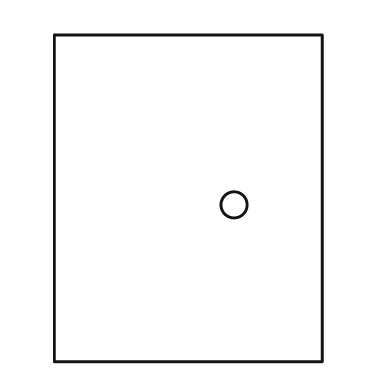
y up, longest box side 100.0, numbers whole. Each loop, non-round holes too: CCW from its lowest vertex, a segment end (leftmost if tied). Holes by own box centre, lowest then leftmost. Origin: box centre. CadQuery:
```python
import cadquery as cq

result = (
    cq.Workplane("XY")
    .moveTo(-41.0, -50.0)
    .lineTo(41.0, -50.0)
    .lineTo(41.0, 50.0)
    .lineTo(-41.0, 50.0)
    .close()
    .moveTo(14.0, -2.0)
    .circle(4.0)
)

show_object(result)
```